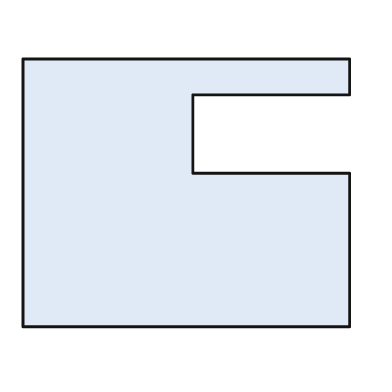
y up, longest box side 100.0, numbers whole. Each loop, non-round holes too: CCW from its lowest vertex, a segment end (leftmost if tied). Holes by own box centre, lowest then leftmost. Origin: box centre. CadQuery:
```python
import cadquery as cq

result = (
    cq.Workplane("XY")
    .moveTo(-50.0, -41.0)
    .lineTo(50.0, -41.0)
    .lineTo(50.0, 6.0)
    .lineTo(2.0, 6.0)
    .lineTo(2.0, 30.0)
    .lineTo(50.0, 30.0)
    .lineTo(50.0, 41.0)
    .lineTo(-50.0, 41.0)
    .close()
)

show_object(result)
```